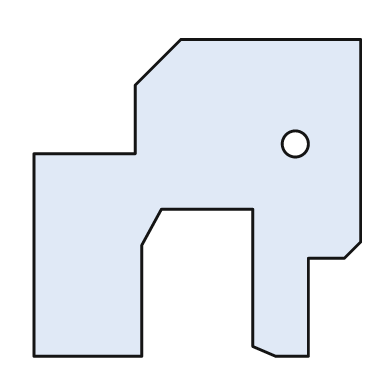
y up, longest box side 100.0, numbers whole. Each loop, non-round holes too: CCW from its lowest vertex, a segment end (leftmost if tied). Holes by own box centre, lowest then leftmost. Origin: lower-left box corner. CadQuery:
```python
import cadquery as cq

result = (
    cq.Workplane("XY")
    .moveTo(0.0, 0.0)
    .lineTo(33.0, 0.0)
    .lineTo(33.0, 34.0)
    .lineTo(39.0, 45.0)
    .lineTo(67.0, 45.0)
    .lineTo(67.0, 3.0)
    .lineTo(74.0, 0.0)
    .lineTo(84.0, 0.0)
    .lineTo(84.0, 30.0)
    .lineTo(95.0, 30.0)
    .lineTo(100.0, 35.0)
    .lineTo(100.0, 97.0)
    .lineTo(45.0, 97.0)
    .lineTo(31.0, 83.0)
    .lineTo(31.0, 62.0)
    .lineTo(0.0, 62.0)
    .close()
    .moveTo(80.0, 65.0)
    .circle(4.0)
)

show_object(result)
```